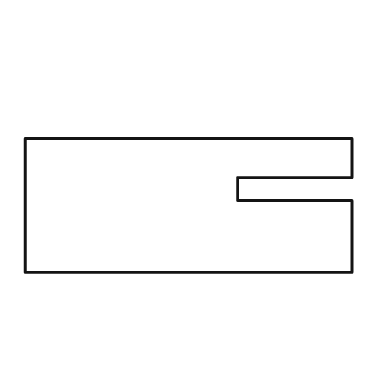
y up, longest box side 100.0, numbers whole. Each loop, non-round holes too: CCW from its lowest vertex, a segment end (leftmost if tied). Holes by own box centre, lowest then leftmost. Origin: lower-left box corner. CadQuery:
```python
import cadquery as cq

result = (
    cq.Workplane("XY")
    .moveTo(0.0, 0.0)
    .lineTo(100.0, 0.0)
    .lineTo(100.0, 22.0)
    .lineTo(65.0, 22.0)
    .lineTo(65.0, 29.0)
    .lineTo(100.0, 29.0)
    .lineTo(100.0, 41.0)
    .lineTo(0.0, 41.0)
    .close()
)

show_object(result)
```